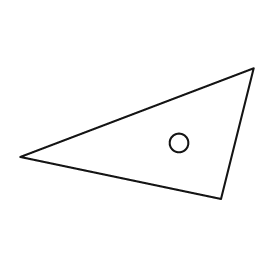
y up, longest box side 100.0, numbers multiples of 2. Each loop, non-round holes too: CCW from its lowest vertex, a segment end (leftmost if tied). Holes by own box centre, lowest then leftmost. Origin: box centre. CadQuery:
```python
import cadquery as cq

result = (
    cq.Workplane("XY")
    .moveTo(36.0, -28.0)
    .lineTo(50.0, 28.0)
    .lineTo(-50.0, -10.0)
    .close()
    .moveTo(18.0, -4.0)
    .circle(4.0)
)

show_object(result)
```